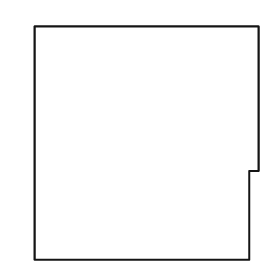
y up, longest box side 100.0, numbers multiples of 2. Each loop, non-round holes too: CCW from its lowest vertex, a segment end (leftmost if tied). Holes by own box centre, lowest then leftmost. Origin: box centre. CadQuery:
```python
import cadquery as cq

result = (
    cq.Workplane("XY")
    .moveTo(-48.0, -50.0)
    .lineTo(44.0, -50.0)
    .lineTo(44.0, -12.0)
    .lineTo(48.0, -12.0)
    .lineTo(48.0, 50.0)
    .lineTo(-48.0, 50.0)
    .close()
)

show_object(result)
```